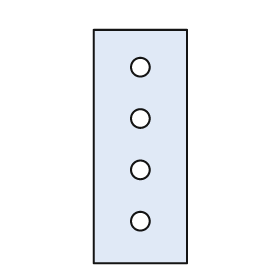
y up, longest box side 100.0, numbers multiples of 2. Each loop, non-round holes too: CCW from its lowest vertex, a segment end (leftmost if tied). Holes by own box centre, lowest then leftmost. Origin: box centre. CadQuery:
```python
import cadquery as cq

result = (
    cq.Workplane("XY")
    .moveTo(-20.0, -50.0)
    .lineTo(20.0, -50.0)
    .lineTo(20.0, 50.0)
    .lineTo(-20.0, 50.0)
    .close()
    .moveTo(0.0, -32.0)
    .circle(4.0)
    .moveTo(0.0, -10.0)
    .circle(4.0)
    .moveTo(0.0, 12.0)
    .circle(4.0)
    .moveTo(0.0, 34.0)
    .circle(4.0)
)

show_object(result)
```